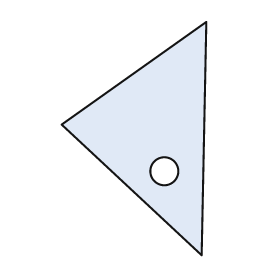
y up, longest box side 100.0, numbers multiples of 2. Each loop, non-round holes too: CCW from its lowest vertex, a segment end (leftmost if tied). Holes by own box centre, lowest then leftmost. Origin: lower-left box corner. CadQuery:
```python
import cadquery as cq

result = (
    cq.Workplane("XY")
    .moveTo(60.0, 0.0)
    .lineTo(62.0, 100.0)
    .lineTo(0.0, 56.0)
    .close()
    .moveTo(44.0, 36.0)
    .circle(6.0)
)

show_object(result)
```